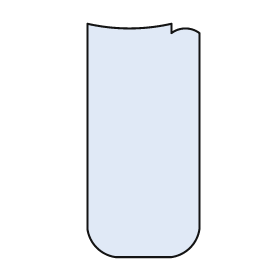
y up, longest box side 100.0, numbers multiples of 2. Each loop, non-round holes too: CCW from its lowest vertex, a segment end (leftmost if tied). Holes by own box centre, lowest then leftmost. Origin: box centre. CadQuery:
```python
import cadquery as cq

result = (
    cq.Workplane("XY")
    .moveTo(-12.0, -50.0)
    .lineTo(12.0, -50.0)
    .threePointArc((20.0, -46.0), (24.0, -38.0))
    .lineTo(24.0, 46.0)
    .threePointArc((18.0, 48.0), (12.0, 46.0))
    .lineTo(12.0, 50.0)
    .threePointArc((-6.0, 48.0), (-24.0, 50.0))
    .lineTo(-24.0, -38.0)
    .threePointArc((-20.0, -46.0), (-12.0, -50.0))
    .close()
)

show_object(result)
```